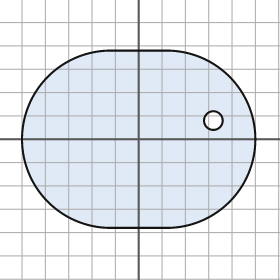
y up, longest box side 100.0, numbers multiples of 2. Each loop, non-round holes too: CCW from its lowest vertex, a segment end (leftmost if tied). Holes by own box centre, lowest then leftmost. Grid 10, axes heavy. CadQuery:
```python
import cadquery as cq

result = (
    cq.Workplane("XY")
    .moveTo(-12.0, -38.0)
    .lineTo(12.0, -38.0)
    .threePointArc((50.0, 0.0), (12.0, 38.0))
    .lineTo(-12.0, 38.0)
    .threePointArc((-50.0, 0.0), (-12.0, -38.0))
    .close()
    .moveTo(32.0, 8.0)
    .circle(4.0)
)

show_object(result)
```